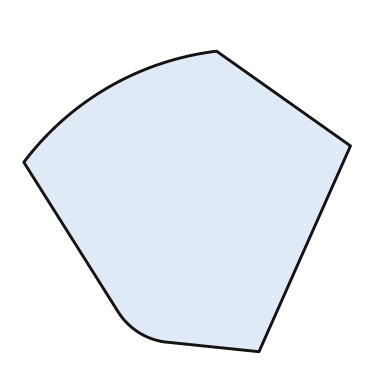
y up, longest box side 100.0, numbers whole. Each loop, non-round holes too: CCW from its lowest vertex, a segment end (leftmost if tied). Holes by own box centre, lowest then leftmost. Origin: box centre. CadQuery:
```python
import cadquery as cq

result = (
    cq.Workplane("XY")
    .moveTo(22.0, -46.0)
    .lineTo(50.0, 17.0)
    .lineTo(9.0, 46.0)
    .threePointArc((-24.0, 35.0), (-50.0, 12.0))
    .lineTo(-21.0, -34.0)
    .threePointArc((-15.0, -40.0), (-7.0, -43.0))
    .close()
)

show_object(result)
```